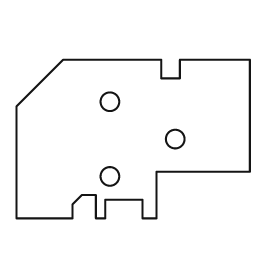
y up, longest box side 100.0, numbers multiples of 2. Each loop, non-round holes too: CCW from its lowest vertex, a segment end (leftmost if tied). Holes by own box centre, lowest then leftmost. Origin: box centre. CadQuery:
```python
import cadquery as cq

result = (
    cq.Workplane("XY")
    .moveTo(-50.0, -34.0)
    .lineTo(-26.0, -34.0)
    .lineTo(-26.0, -28.0)
    .lineTo(-22.0, -24.0)
    .lineTo(-16.0, -24.0)
    .lineTo(-16.0, -34.0)
    .lineTo(-12.0, -34.0)
    .lineTo(-12.0, -26.0)
    .lineTo(4.0, -26.0)
    .lineTo(4.0, -34.0)
    .lineTo(10.0, -34.0)
    .lineTo(10.0, -14.0)
    .lineTo(50.0, -14.0)
    .lineTo(50.0, 34.0)
    .lineTo(20.0, 34.0)
    .lineTo(20.0, 26.0)
    .lineTo(12.0, 26.0)
    .lineTo(12.0, 34.0)
    .lineTo(-30.0, 34.0)
    .lineTo(-50.0, 14.0)
    .close()
    .moveTo(-10.0, -16.0)
    .circle(4.0)
    .moveTo(18.0, 0.0)
    .circle(4.0)
    .moveTo(-10.0, 16.0)
    .circle(4.0)
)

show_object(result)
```